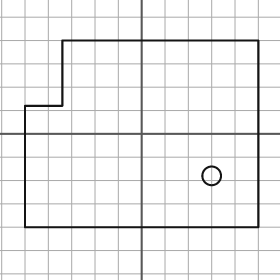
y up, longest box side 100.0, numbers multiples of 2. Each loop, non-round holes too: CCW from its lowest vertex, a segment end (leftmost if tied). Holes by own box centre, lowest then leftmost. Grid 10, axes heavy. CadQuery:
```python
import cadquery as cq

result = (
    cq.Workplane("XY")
    .moveTo(-50.0, -40.0)
    .lineTo(50.0, -40.0)
    .lineTo(50.0, 40.0)
    .lineTo(-34.0, 40.0)
    .lineTo(-34.0, 12.0)
    .lineTo(-50.0, 12.0)
    .close()
    .moveTo(30.0, -18.0)
    .circle(4.0)
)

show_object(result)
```